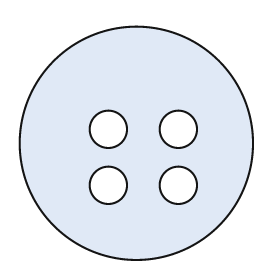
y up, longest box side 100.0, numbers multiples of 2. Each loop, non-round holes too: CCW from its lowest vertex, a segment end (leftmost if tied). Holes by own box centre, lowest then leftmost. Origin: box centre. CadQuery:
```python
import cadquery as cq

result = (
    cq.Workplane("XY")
    .moveTo(0.0, 0.0)
    .circle(50.0)
    .moveTo(-12.0, -18.0)
    .circle(8.0)
    .moveTo(18.0, -18.0)
    .circle(8.0)
    .moveTo(-12.0, 6.0)
    .circle(8.0)
    .moveTo(18.0, 6.0)
    .circle(8.0)
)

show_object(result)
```